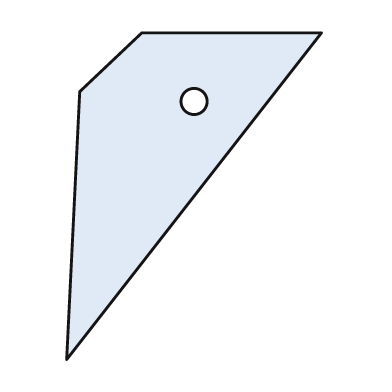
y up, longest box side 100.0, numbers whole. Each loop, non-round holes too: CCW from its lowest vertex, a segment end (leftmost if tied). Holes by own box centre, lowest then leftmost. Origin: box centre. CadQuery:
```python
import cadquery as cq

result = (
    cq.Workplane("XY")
    .moveTo(-39.0, -50.0)
    .lineTo(39.0, 50.0)
    .lineTo(-16.0, 50.0)
    .lineTo(-35.0, 32.0)
    .close()
    .moveTo(0.0, 29.0)
    .circle(4.0)
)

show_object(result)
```